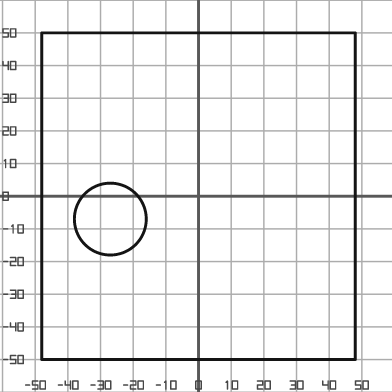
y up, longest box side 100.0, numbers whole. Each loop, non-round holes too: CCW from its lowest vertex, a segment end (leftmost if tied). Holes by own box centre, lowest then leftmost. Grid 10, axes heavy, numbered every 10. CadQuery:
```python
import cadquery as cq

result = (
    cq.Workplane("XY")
    .moveTo(-48.0, -50.0)
    .lineTo(48.0, -50.0)
    .lineTo(48.0, 50.0)
    .lineTo(-48.0, 50.0)
    .close()
    .moveTo(-27.0, -7.0)
    .circle(11.0)
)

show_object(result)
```